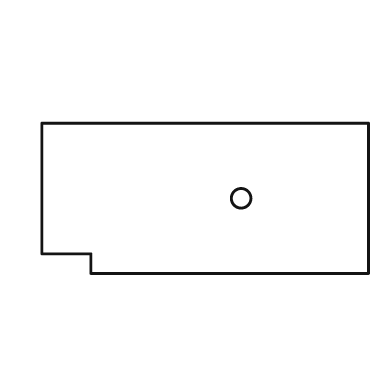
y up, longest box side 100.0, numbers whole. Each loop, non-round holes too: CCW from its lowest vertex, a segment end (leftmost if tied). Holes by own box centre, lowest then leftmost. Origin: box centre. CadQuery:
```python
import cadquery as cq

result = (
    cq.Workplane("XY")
    .moveTo(-35.0, -23.0)
    .lineTo(50.0, -23.0)
    .lineTo(50.0, 23.0)
    .lineTo(-50.0, 23.0)
    .lineTo(-50.0, -17.0)
    .lineTo(-35.0, -17.0)
    .close()
    .moveTo(11.0, 0.0)
    .circle(3.0)
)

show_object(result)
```